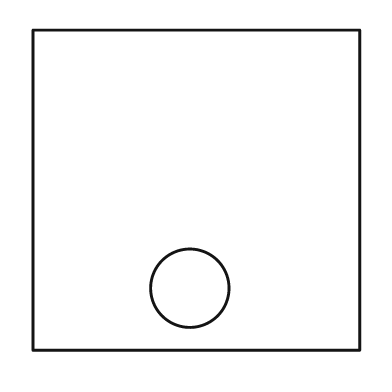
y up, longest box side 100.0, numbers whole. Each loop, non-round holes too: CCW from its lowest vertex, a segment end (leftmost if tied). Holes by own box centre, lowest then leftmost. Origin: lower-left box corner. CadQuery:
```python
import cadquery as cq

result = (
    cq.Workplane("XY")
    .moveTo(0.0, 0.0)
    .lineTo(100.0, 0.0)
    .lineTo(100.0, 98.0)
    .lineTo(0.0, 98.0)
    .close()
    .moveTo(48.0, 19.0)
    .circle(12.0)
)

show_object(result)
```